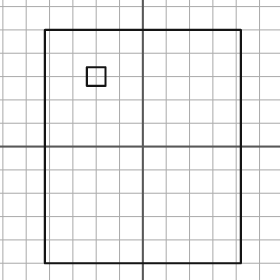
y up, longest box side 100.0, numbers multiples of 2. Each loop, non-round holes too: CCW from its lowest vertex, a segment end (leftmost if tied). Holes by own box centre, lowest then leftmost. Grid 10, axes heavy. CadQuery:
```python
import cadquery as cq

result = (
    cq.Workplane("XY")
    .moveTo(-42.0, -50.0)
    .lineTo(42.0, -50.0)
    .lineTo(42.0, 50.0)
    .lineTo(-42.0, 50.0)
    .close()
    .moveTo(-24.0, 26.0)
    .lineTo(-16.0, 26.0)
    .lineTo(-16.0, 34.0)
    .lineTo(-24.0, 34.0)
    .close()
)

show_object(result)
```